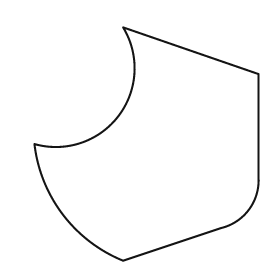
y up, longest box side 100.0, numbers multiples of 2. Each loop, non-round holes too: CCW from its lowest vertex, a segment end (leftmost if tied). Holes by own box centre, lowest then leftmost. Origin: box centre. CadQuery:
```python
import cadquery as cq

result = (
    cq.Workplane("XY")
    .moveTo(-10.0, -50.0)
    .lineTo(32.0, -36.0)
    .threePointArc((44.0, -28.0), (48.0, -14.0))
    .lineTo(48.0, 30.0)
    .lineTo(-10.0, 50.0)
    .threePointArc((-12.0, 12.0), (-48.0, 0.0))
    .threePointArc((-36.0, -30.0), (-10.0, -50.0))
    .close()
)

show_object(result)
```